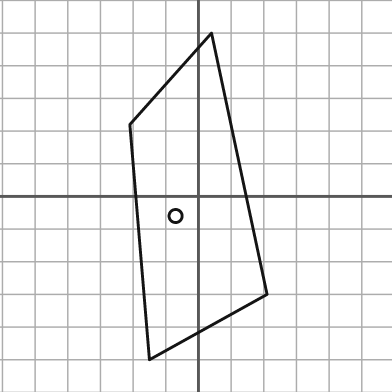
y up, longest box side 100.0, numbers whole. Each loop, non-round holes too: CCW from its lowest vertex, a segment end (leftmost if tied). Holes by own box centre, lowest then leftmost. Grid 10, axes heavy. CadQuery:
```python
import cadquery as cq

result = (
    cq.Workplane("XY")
    .moveTo(-15.0, -50.0)
    .lineTo(21.0, -30.0)
    .lineTo(4.0, 50.0)
    .lineTo(-21.0, 22.0)
    .close()
    .moveTo(-7.0, -6.0)
    .circle(2.0)
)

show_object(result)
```